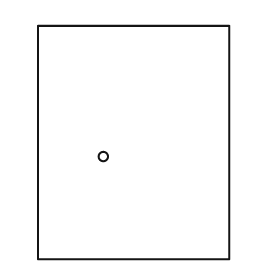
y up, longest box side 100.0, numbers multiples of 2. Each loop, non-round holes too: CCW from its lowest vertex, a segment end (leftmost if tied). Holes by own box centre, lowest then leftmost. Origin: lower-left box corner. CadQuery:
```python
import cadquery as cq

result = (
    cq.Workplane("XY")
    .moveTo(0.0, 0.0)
    .lineTo(82.0, 0.0)
    .lineTo(82.0, 100.0)
    .lineTo(0.0, 100.0)
    .close()
    .moveTo(28.0, 44.0)
    .circle(2.0)
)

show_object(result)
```